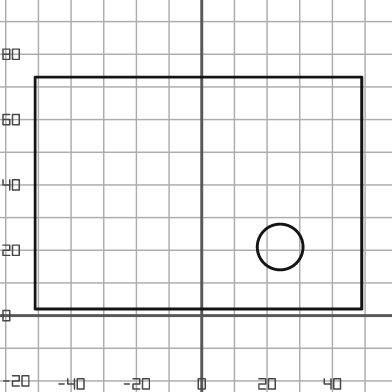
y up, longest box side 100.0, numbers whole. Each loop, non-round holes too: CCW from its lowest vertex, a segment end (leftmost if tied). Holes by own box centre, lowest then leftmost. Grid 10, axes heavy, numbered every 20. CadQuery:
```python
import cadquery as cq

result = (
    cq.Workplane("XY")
    .moveTo(-51.0, 2.0)
    .lineTo(49.0, 2.0)
    .lineTo(49.0, 73.0)
    .lineTo(-51.0, 73.0)
    .close()
    .moveTo(24.0, 21.0)
    .circle(7.0)
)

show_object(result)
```